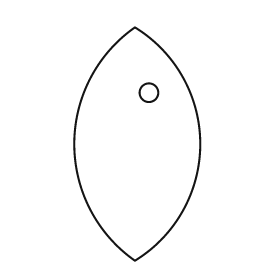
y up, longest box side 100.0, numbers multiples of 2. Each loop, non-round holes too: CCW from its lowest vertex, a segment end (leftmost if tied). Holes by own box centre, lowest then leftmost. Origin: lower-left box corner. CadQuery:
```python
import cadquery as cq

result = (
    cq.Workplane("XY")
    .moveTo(26.0, 0.0)
    .threePointArc((54.0, 50.0), (26.0, 100.0))
    .threePointArc((0.0, 50.0), (26.0, 0.0))
    .close()
    .moveTo(32.0, 72.0)
    .circle(4.0)
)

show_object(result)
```